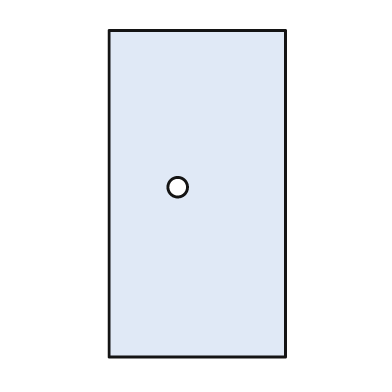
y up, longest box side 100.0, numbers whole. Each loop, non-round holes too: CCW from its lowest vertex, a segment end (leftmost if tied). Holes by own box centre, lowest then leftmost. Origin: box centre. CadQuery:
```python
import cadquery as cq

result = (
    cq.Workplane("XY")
    .moveTo(-27.0, -50.0)
    .lineTo(27.0, -50.0)
    .lineTo(27.0, 50.0)
    .lineTo(-27.0, 50.0)
    .close()
    .moveTo(-6.0, 2.0)
    .circle(3.0)
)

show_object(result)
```